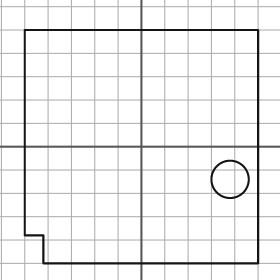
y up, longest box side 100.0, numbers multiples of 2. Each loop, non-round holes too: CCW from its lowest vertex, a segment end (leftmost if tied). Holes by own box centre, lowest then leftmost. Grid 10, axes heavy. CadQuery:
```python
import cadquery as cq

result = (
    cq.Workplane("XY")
    .moveTo(-42.0, -50.0)
    .lineTo(50.0, -50.0)
    .lineTo(50.0, 50.0)
    .lineTo(-50.0, 50.0)
    .lineTo(-50.0, -38.0)
    .lineTo(-42.0, -38.0)
    .close()
    .moveTo(38.0, -14.0)
    .circle(8.0)
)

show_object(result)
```